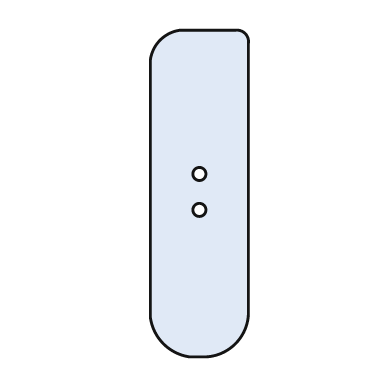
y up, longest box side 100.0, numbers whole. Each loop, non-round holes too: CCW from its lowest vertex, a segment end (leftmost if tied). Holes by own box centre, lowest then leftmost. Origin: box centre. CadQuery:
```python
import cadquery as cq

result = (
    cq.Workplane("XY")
    .moveTo(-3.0, -50.0)
    .lineTo(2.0, -50.0)
    .threePointArc((11.0, -46.0), (15.0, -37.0))
    .lineTo(15.0, 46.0)
    .threePointArc((14.0, 49.0), (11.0, 50.0))
    .lineTo(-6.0, 50.0)
    .threePointArc((-12.0, 47.0), (-15.0, 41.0))
    .lineTo(-15.0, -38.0)
    .threePointArc((-11.0, -46.0), (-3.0, -50.0))
    .close()
    .moveTo(0.0, -5.0)
    .circle(2.0)
    .moveTo(0.0, 6.0)
    .circle(2.0)
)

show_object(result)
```